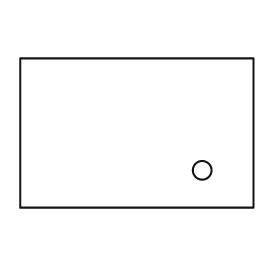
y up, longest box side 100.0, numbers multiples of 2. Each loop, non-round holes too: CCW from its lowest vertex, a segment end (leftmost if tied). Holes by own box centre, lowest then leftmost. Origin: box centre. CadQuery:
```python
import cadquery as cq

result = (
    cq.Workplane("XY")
    .moveTo(-50.0, -32.0)
    .lineTo(50.0, -32.0)
    .lineTo(50.0, 32.0)
    .lineTo(-50.0, 32.0)
    .close()
    .moveTo(28.0, -16.0)
    .circle(4.0)
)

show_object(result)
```